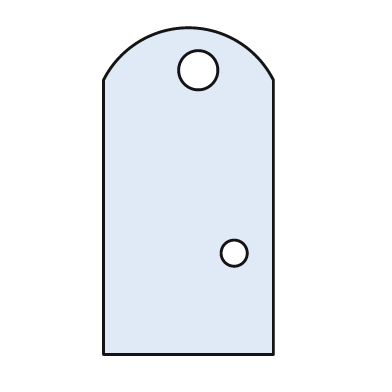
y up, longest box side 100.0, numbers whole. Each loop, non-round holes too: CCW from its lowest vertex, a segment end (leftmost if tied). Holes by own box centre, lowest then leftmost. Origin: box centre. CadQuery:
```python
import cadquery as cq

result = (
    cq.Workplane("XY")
    .moveTo(-26.0, -50.0)
    .lineTo(26.0, -50.0)
    .lineTo(26.0, 34.0)
    .threePointArc((0.0, 50.0), (-26.0, 34.0))
    .close()
    .moveTo(14.0, -19.0)
    .circle(4.0)
    .moveTo(3.0, 37.0)
    .circle(6.0)
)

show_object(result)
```